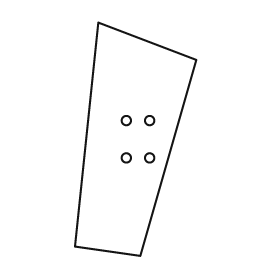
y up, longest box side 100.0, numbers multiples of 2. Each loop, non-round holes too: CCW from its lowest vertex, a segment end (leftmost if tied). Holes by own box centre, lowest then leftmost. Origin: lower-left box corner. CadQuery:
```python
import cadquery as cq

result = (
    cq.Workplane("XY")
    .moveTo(28.0, 0.0)
    .lineTo(52.0, 84.0)
    .lineTo(10.0, 100.0)
    .lineTo(0.0, 4.0)
    .close()
    .moveTo(22.0, 42.0)
    .circle(2.0)
    .moveTo(32.0, 42.0)
    .circle(2.0)
    .moveTo(22.0, 58.0)
    .circle(2.0)
    .moveTo(32.0, 58.0)
    .circle(2.0)
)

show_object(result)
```